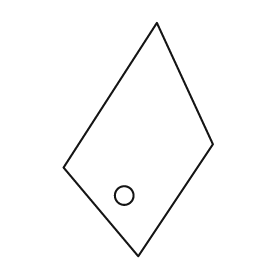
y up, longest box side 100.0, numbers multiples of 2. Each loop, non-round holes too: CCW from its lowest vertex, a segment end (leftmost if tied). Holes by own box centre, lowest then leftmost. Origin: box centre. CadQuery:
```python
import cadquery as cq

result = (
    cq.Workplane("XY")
    .moveTo(0.0, -50.0)
    .lineTo(32.0, -2.0)
    .lineTo(8.0, 50.0)
    .lineTo(-32.0, -12.0)
    .close()
    .moveTo(-6.0, -24.0)
    .circle(4.0)
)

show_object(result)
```